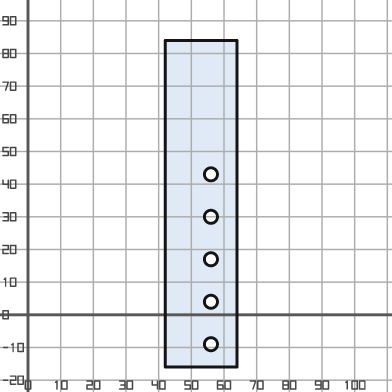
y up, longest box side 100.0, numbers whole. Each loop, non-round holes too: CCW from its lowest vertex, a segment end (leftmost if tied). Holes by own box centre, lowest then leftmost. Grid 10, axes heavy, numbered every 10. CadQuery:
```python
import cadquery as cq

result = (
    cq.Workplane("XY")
    .moveTo(42.0, -16.0)
    .lineTo(64.0, -16.0)
    .lineTo(64.0, 84.0)
    .lineTo(42.0, 84.0)
    .close()
    .moveTo(56.0, -9.0)
    .circle(2.0)
    .moveTo(56.0, 4.0)
    .circle(2.0)
    .moveTo(56.0, 17.0)
    .circle(2.0)
    .moveTo(56.0, 30.0)
    .circle(2.0)
    .moveTo(56.0, 43.0)
    .circle(2.0)
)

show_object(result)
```